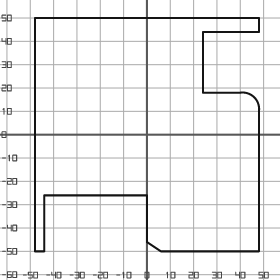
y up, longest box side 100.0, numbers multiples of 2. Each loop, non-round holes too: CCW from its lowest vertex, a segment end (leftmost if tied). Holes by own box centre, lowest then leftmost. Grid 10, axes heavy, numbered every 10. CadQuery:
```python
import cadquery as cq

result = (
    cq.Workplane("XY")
    .moveTo(-48.0, -50.0)
    .lineTo(-44.0, -50.0)
    .lineTo(-44.0, -26.0)
    .lineTo(0.0, -26.0)
    .lineTo(0.0, -46.0)
    .lineTo(6.0, -50.0)
    .lineTo(48.0, -50.0)
    .lineTo(48.0, 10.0)
    .threePointArc((46.0, 16.0), (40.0, 18.0))
    .lineTo(24.0, 18.0)
    .lineTo(24.0, 44.0)
    .lineTo(48.0, 44.0)
    .lineTo(48.0, 50.0)
    .lineTo(-48.0, 50.0)
    .close()
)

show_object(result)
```